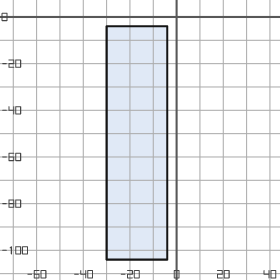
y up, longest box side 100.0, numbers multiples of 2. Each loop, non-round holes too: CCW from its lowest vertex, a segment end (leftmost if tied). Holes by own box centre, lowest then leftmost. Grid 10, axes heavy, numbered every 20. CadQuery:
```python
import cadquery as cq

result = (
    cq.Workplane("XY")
    .moveTo(-30.0, -104.0)
    .lineTo(-4.0, -104.0)
    .lineTo(-4.0, -4.0)
    .lineTo(-30.0, -4.0)
    .close()
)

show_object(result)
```